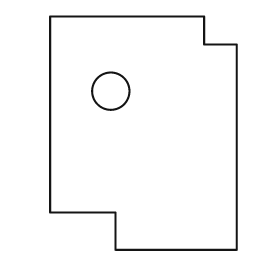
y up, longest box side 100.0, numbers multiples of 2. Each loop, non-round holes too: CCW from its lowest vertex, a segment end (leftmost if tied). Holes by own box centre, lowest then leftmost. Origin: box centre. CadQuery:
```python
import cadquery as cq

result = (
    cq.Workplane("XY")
    .moveTo(-12.0, -50.0)
    .lineTo(40.0, -50.0)
    .lineTo(40.0, 38.0)
    .lineTo(26.0, 38.0)
    .lineTo(26.0, 50.0)
    .lineTo(-40.0, 50.0)
    .lineTo(-40.0, -34.0)
    .lineTo(-12.0, -34.0)
    .close()
    .moveTo(-14.0, 18.0)
    .circle(8.0)
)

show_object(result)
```